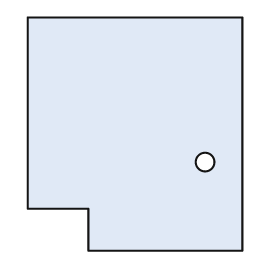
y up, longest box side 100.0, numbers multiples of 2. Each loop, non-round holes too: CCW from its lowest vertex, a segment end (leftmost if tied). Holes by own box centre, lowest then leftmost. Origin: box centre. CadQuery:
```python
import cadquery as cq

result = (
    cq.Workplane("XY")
    .moveTo(-20.0, -50.0)
    .lineTo(46.0, -50.0)
    .lineTo(46.0, 50.0)
    .lineTo(-46.0, 50.0)
    .lineTo(-46.0, -32.0)
    .lineTo(-20.0, -32.0)
    .close()
    .moveTo(30.0, -12.0)
    .circle(4.0)
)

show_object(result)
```